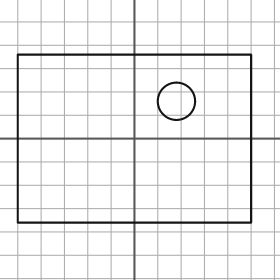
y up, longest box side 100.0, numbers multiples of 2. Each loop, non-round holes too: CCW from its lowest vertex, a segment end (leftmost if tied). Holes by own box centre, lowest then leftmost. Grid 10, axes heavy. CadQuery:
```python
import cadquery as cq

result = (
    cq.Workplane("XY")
    .moveTo(-50.0, -36.0)
    .lineTo(50.0, -36.0)
    .lineTo(50.0, 36.0)
    .lineTo(-50.0, 36.0)
    .close()
    .moveTo(18.0, 16.0)
    .circle(8.0)
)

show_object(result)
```